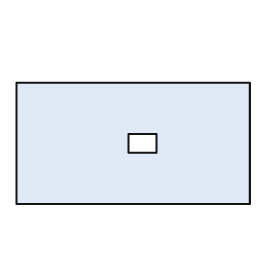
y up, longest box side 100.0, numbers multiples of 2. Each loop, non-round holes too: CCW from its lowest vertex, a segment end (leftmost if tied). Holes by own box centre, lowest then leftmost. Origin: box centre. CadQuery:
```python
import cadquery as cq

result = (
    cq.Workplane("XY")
    .moveTo(-50.0, -26.0)
    .lineTo(50.0, -26.0)
    .lineTo(50.0, 26.0)
    .lineTo(-50.0, 26.0)
    .close()
    .moveTo(-2.0, -4.0)
    .lineTo(10.0, -4.0)
    .lineTo(10.0, 4.0)
    .lineTo(-2.0, 4.0)
    .close()
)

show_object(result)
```